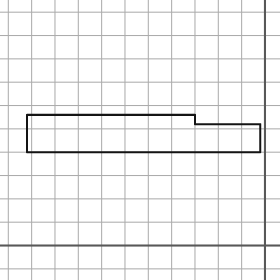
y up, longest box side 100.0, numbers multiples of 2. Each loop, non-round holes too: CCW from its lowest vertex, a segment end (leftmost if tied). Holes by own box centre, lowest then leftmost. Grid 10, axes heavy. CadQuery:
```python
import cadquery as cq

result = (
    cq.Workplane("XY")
    .moveTo(-102.0, 40.0)
    .lineTo(-2.0, 40.0)
    .lineTo(-2.0, 52.0)
    .lineTo(-30.0, 52.0)
    .lineTo(-30.0, 56.0)
    .lineTo(-102.0, 56.0)
    .close()
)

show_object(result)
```